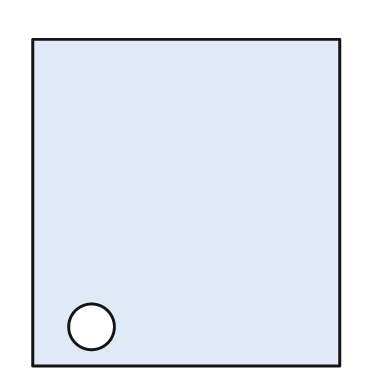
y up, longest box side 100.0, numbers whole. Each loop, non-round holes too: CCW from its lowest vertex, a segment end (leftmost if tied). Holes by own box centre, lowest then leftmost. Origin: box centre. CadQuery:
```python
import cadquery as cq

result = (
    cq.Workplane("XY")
    .moveTo(-47.0, -50.0)
    .lineTo(47.0, -50.0)
    .lineTo(47.0, 50.0)
    .lineTo(-47.0, 50.0)
    .close()
    .moveTo(-29.0, -38.0)
    .circle(7.0)
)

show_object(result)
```